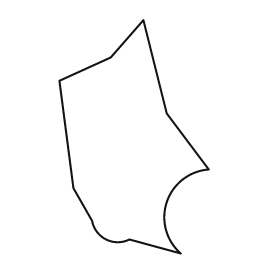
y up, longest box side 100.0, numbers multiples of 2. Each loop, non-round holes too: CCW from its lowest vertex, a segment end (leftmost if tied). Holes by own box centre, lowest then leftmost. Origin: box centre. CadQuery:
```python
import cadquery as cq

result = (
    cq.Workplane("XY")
    .moveTo(20.0, -50.0)
    .threePointArc((14.0, -28.0), (32.0, -14.0))
    .lineTo(14.0, 10.0)
    .lineTo(4.0, 50.0)
    .lineTo(-10.0, 34.0)
    .lineTo(-32.0, 24.0)
    .lineTo(-26.0, -22.0)
    .lineTo(-18.0, -36.0)
    .threePointArc((-12.0, -44.0), (-2.0, -44.0))
    .close()
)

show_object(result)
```